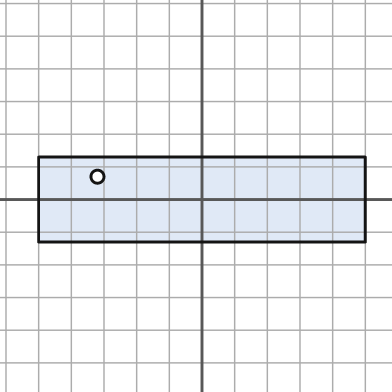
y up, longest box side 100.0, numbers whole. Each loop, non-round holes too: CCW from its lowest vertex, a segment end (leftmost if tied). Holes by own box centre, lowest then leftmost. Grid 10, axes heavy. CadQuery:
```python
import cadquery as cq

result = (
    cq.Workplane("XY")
    .moveTo(-50.0, -13.0)
    .lineTo(50.0, -13.0)
    .lineTo(50.0, 13.0)
    .lineTo(-50.0, 13.0)
    .close()
    .moveTo(-32.0, 7.0)
    .circle(2.0)
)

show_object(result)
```